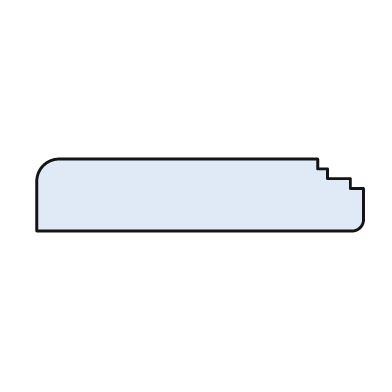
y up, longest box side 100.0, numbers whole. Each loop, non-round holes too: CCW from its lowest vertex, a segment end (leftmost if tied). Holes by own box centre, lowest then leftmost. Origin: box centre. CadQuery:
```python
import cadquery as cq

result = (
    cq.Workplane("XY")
    .moveTo(-50.0, -11.0)
    .lineTo(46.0, -11.0)
    .threePointArc((49.0, -10.0), (50.0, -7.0))
    .lineTo(50.0, 2.0)
    .lineTo(46.0, 2.0)
    .lineTo(46.0, 5.0)
    .lineTo(39.0, 5.0)
    .lineTo(39.0, 8.0)
    .lineTo(36.0, 8.0)
    .lineTo(36.0, 11.0)
    .lineTo(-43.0, 11.0)
    .threePointArc((-48.0, 9.0), (-50.0, 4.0))
    .close()
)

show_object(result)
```